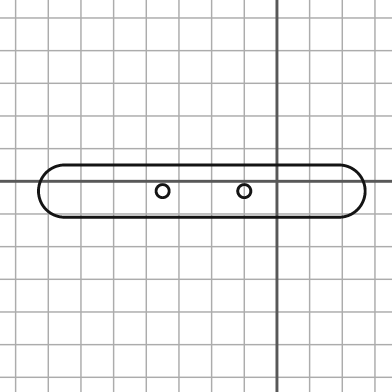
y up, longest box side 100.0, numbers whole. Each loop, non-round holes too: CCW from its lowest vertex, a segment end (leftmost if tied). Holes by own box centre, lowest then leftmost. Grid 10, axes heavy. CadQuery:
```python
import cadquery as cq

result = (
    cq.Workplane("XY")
    .moveTo(-65.0, -11.0)
    .lineTo(19.0, -11.0)
    .threePointArc((27.0, -3.0), (19.0, 5.0))
    .lineTo(-65.0, 5.0)
    .threePointArc((-73.0, -3.0), (-65.0, -11.0))
    .close()
    .moveTo(-35.0, -3.0)
    .circle(2.0)
    .moveTo(-10.0, -3.0)
    .circle(2.0)
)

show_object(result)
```